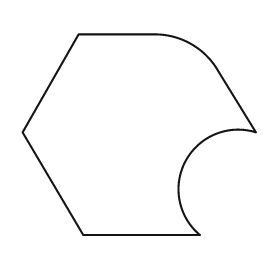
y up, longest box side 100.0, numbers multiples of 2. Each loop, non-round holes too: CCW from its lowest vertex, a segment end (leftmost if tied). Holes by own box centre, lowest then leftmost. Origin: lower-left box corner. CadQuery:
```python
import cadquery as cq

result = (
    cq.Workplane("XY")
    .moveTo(26.0, 0.0)
    .lineTo(76.0, 0.0)
    .threePointArc((70.0, 32.0), (100.0, 44.0))
    .lineTo(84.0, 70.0)
    .threePointArc((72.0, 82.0), (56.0, 86.0))
    .lineTo(24.0, 86.0)
    .lineTo(0.0, 44.0)
    .close()
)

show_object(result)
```